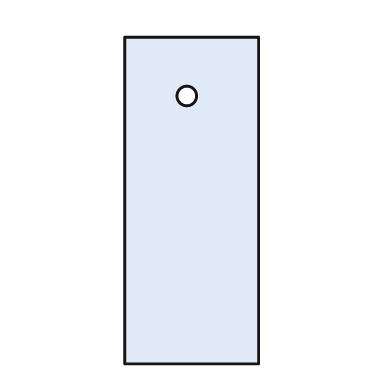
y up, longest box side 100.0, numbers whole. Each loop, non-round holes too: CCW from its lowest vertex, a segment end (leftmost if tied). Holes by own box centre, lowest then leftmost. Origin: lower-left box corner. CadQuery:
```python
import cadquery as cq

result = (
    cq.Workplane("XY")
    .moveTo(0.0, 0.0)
    .lineTo(41.0, 0.0)
    .lineTo(41.0, 100.0)
    .lineTo(0.0, 100.0)
    .close()
    .moveTo(19.0, 82.0)
    .circle(3.0)
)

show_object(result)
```